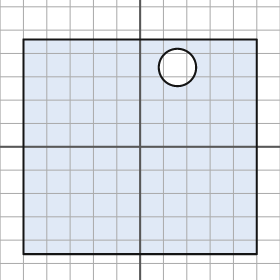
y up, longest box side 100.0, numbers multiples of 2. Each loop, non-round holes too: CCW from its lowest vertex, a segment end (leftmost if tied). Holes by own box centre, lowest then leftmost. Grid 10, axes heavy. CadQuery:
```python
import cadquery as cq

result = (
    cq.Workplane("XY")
    .moveTo(-50.0, -46.0)
    .lineTo(50.0, -46.0)
    .lineTo(50.0, 46.0)
    .lineTo(-50.0, 46.0)
    .close()
    .moveTo(16.0, 34.0)
    .circle(8.0)
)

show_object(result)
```